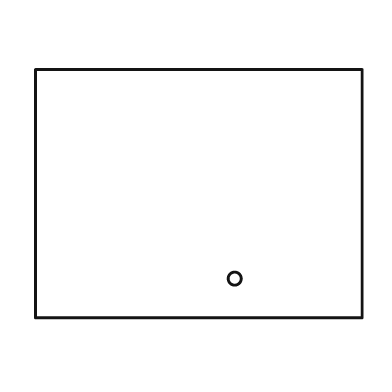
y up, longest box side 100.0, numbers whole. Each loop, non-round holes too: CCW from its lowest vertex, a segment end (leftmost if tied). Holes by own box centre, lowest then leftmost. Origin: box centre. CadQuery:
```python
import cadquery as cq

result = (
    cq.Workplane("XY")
    .moveTo(-50.0, -38.0)
    .lineTo(50.0, -38.0)
    .lineTo(50.0, 38.0)
    .lineTo(-50.0, 38.0)
    .close()
    .moveTo(11.0, -26.0)
    .circle(2.0)
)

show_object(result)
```